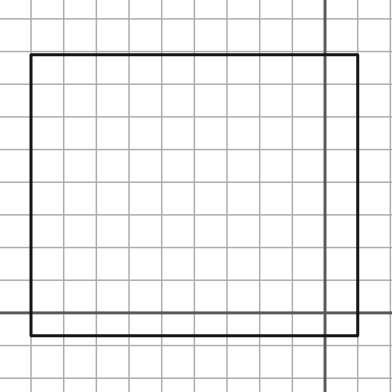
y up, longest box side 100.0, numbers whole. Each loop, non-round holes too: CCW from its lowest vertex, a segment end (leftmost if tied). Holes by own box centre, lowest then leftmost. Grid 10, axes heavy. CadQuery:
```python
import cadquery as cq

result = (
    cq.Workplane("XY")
    .moveTo(-90.0, -7.0)
    .lineTo(10.0, -7.0)
    .lineTo(10.0, 79.0)
    .lineTo(-90.0, 79.0)
    .close()
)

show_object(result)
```